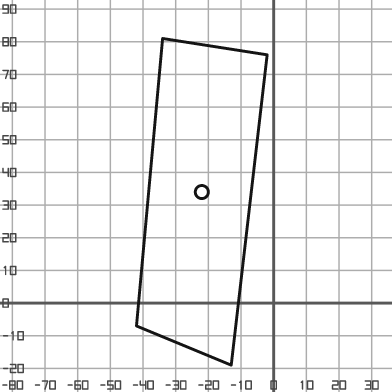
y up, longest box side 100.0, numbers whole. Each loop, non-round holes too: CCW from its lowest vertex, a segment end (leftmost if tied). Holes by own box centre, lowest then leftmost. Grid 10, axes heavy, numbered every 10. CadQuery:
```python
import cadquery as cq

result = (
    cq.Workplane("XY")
    .moveTo(-13.0, -19.0)
    .lineTo(-2.0, 76.0)
    .lineTo(-34.0, 81.0)
    .lineTo(-42.0, -7.0)
    .close()
    .moveTo(-22.0, 34.0)
    .circle(2.0)
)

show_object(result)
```